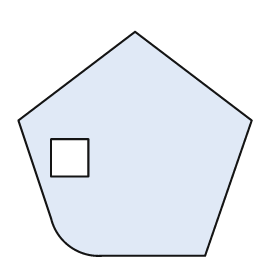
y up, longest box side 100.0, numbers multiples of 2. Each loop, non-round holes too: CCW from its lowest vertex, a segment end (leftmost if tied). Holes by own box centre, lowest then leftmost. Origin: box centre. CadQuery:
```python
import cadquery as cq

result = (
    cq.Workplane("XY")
    .moveTo(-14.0, -48.0)
    .lineTo(30.0, -48.0)
    .lineTo(50.0, 10.0)
    .lineTo(0.0, 48.0)
    .lineTo(-50.0, 10.0)
    .lineTo(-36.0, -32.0)
    .threePointArc((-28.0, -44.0), (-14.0, -48.0))
    .close()
    .moveTo(-36.0, -14.0)
    .lineTo(-20.0, -14.0)
    .lineTo(-20.0, 2.0)
    .lineTo(-36.0, 2.0)
    .close()
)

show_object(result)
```